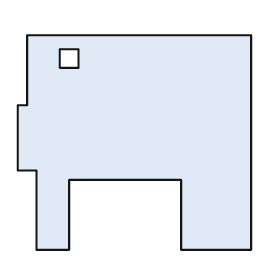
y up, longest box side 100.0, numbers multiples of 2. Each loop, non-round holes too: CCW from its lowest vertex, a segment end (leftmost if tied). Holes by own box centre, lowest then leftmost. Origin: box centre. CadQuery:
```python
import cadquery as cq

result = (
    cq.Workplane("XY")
    .moveTo(-42.0, -46.0)
    .lineTo(-28.0, -46.0)
    .lineTo(-28.0, -16.0)
    .lineTo(20.0, -16.0)
    .lineTo(20.0, -46.0)
    .lineTo(50.0, -46.0)
    .lineTo(50.0, 46.0)
    .lineTo(-46.0, 46.0)
    .lineTo(-46.0, 16.0)
    .lineTo(-50.0, 16.0)
    .lineTo(-50.0, -12.0)
    .lineTo(-42.0, -12.0)
    .close()
    .moveTo(-32.0, 32.0)
    .lineTo(-24.0, 32.0)
    .lineTo(-24.0, 40.0)
    .lineTo(-32.0, 40.0)
    .close()
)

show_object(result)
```